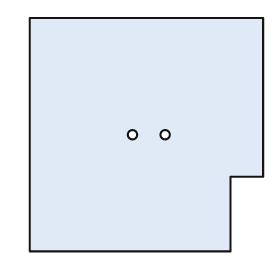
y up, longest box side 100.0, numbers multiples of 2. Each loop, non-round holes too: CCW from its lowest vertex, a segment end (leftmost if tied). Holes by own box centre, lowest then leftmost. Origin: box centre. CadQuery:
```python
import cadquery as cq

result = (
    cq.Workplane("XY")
    .moveTo(-50.0, -50.0)
    .lineTo(36.0, -50.0)
    .lineTo(36.0, -18.0)
    .lineTo(50.0, -18.0)
    .lineTo(50.0, 50.0)
    .lineTo(-50.0, 50.0)
    .close()
    .moveTo(-6.0, 0.0)
    .circle(2.0)
    .moveTo(8.0, 0.0)
    .circle(2.0)
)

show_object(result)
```